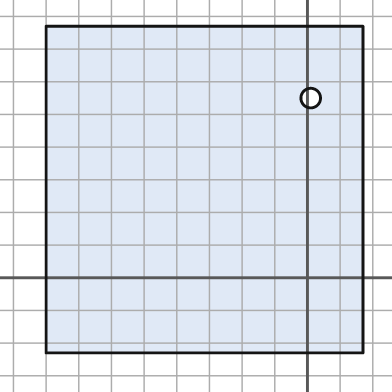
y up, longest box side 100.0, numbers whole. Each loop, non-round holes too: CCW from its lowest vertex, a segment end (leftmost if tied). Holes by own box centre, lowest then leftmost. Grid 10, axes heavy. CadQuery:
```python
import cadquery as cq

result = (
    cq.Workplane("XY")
    .moveTo(-80.0, -23.0)
    .lineTo(17.0, -23.0)
    .lineTo(17.0, 77.0)
    .lineTo(-80.0, 77.0)
    .close()
    .moveTo(1.0, 55.0)
    .circle(3.0)
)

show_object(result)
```